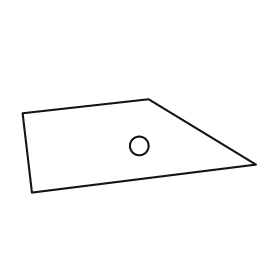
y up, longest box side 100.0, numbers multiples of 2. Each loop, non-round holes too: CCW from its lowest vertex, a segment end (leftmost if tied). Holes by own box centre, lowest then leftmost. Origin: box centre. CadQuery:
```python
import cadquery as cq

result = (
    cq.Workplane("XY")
    .moveTo(-46.0, -20.0)
    .lineTo(50.0, -8.0)
    .lineTo(4.0, 20.0)
    .lineTo(-50.0, 14.0)
    .close()
    .moveTo(0.0, 0.0)
    .circle(4.0)
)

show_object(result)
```